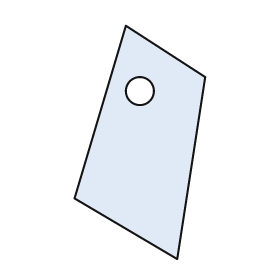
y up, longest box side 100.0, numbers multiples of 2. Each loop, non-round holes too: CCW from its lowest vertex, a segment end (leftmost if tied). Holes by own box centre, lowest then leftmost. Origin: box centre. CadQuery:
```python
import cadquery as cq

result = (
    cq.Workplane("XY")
    .moveTo(16.0, -50.0)
    .lineTo(28.0, 28.0)
    .lineTo(-6.0, 50.0)
    .lineTo(-28.0, -24.0)
    .close()
    .moveTo(0.0, 22.0)
    .circle(6.0)
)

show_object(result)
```